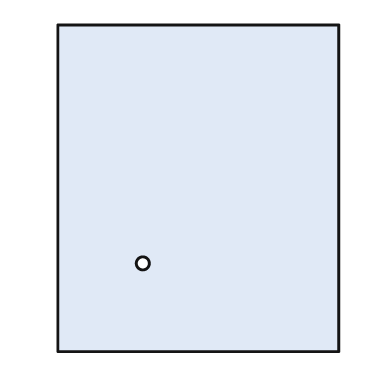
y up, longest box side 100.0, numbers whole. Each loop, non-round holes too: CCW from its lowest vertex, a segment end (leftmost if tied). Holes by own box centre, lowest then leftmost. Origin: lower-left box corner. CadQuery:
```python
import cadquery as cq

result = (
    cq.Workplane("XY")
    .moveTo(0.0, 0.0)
    .lineTo(86.0, 0.0)
    .lineTo(86.0, 100.0)
    .lineTo(0.0, 100.0)
    .close()
    .moveTo(26.0, 27.0)
    .circle(2.0)
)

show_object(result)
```